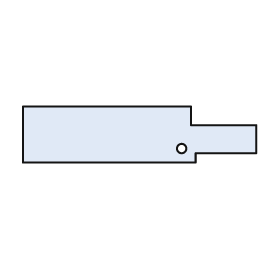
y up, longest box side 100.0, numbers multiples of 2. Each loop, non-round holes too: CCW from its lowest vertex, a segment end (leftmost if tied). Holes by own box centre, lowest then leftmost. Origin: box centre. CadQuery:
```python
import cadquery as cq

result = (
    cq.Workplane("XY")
    .moveTo(-50.0, -12.0)
    .lineTo(24.0, -12.0)
    .lineTo(24.0, -8.0)
    .lineTo(50.0, -8.0)
    .lineTo(50.0, 4.0)
    .lineTo(22.0, 4.0)
    .lineTo(22.0, 12.0)
    .lineTo(-50.0, 12.0)
    .close()
    .moveTo(18.0, -6.0)
    .circle(2.0)
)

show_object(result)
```